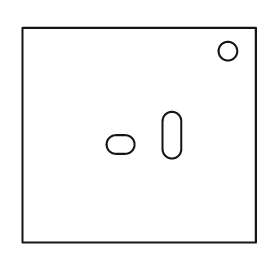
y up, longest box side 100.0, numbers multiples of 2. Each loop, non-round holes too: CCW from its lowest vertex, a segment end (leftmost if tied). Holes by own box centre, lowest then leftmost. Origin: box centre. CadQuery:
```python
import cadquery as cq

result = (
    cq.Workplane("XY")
    .moveTo(-50.0, -46.0)
    .lineTo(50.0, -46.0)
    .lineTo(50.0, 46.0)
    .lineTo(-50.0, 46.0)
    .close()
    .moveTo(-10.0, -8.0)
    .lineTo(-6.0, -8.0)
    .threePointArc((-2.0, -4.0), (-6.0, 0.0))
    .lineTo(-10.0, 0.0)
    .threePointArc((-14.0, -4.0), (-10.0, -8.0))
    .close()
    .moveTo(10.0, -6.0)
    .threePointArc((14.0, -10.0), (18.0, -6.0))
    .lineTo(18.0, 6.0)
    .threePointArc((14.0, 10.0), (10.0, 6.0))
    .close()
    .moveTo(38.0, 36.0)
    .circle(4.0)
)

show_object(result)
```